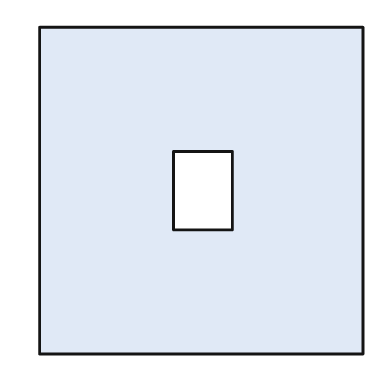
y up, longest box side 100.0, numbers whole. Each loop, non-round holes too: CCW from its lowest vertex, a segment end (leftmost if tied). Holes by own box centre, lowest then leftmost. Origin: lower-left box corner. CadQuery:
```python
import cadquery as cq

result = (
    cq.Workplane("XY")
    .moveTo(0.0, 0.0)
    .lineTo(99.0, 0.0)
    .lineTo(99.0, 100.0)
    .lineTo(0.0, 100.0)
    .close()
    .moveTo(41.0, 38.0)
    .lineTo(59.0, 38.0)
    .lineTo(59.0, 62.0)
    .lineTo(41.0, 62.0)
    .close()
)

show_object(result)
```